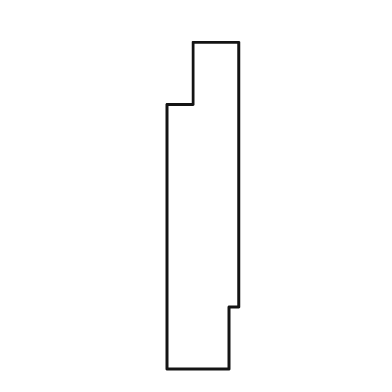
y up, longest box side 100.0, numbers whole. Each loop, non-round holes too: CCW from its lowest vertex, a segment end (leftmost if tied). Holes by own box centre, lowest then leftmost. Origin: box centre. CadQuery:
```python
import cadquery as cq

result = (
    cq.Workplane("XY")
    .moveTo(-11.0, -50.0)
    .lineTo(8.0, -50.0)
    .lineTo(8.0, -31.0)
    .lineTo(11.0, -31.0)
    .lineTo(11.0, 50.0)
    .lineTo(-3.0, 50.0)
    .lineTo(-3.0, 31.0)
    .lineTo(-11.0, 31.0)
    .close()
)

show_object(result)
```